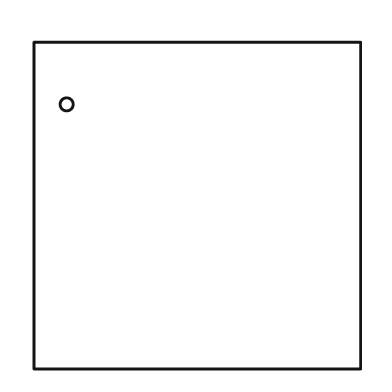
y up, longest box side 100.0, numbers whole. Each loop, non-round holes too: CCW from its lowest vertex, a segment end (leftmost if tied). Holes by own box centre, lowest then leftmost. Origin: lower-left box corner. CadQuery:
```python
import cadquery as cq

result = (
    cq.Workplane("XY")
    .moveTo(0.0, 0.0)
    .lineTo(100.0, 0.0)
    .lineTo(100.0, 100.0)
    .lineTo(0.0, 100.0)
    .close()
    .moveTo(10.0, 81.0)
    .circle(2.0)
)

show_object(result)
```